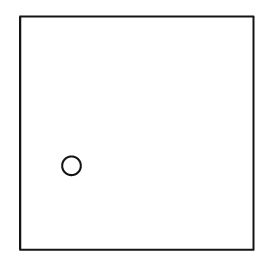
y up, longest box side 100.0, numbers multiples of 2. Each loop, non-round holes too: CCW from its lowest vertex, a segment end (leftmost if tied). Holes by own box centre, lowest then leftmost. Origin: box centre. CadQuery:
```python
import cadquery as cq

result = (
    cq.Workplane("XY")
    .moveTo(-50.0, -50.0)
    .lineTo(50.0, -50.0)
    .lineTo(50.0, 50.0)
    .lineTo(-50.0, 50.0)
    .close()
    .moveTo(-28.0, -14.0)
    .circle(4.0)
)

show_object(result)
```